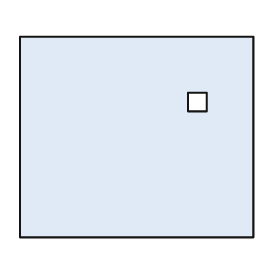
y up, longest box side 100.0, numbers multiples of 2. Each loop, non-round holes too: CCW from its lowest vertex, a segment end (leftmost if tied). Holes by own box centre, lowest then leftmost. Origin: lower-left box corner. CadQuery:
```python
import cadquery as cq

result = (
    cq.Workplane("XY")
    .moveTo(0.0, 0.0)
    .lineTo(100.0, 0.0)
    .lineTo(100.0, 86.0)
    .lineTo(0.0, 86.0)
    .close()
    .moveTo(72.0, 54.0)
    .lineTo(80.0, 54.0)
    .lineTo(80.0, 62.0)
    .lineTo(72.0, 62.0)
    .close()
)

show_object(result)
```